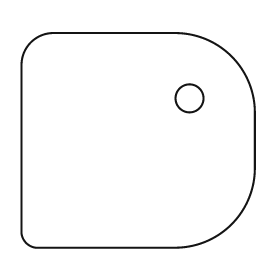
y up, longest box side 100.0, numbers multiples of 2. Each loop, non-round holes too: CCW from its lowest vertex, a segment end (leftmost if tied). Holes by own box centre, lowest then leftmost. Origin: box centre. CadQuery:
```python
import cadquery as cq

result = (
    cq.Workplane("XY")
    .moveTo(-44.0, -46.0)
    .lineTo(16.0, -46.0)
    .threePointArc((40.0, -36.0), (50.0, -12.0))
    .lineTo(50.0, 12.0)
    .threePointArc((40.0, 36.0), (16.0, 46.0))
    .lineTo(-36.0, 46.0)
    .threePointArc((-46.0, 42.0), (-50.0, 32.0))
    .lineTo(-50.0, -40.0)
    .threePointArc((-48.0, -44.0), (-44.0, -46.0))
    .close()
    .moveTo(22.0, 18.0)
    .circle(6.0)
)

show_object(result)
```